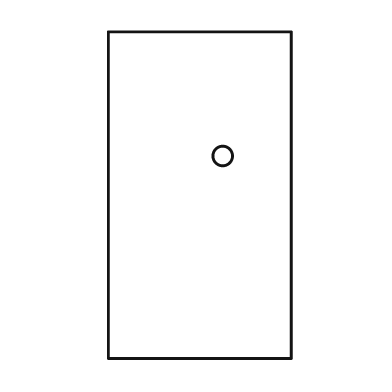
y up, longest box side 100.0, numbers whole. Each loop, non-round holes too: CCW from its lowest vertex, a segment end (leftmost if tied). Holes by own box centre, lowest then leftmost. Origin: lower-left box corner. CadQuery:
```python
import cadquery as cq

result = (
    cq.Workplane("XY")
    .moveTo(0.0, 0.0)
    .lineTo(56.0, 0.0)
    .lineTo(56.0, 100.0)
    .lineTo(0.0, 100.0)
    .close()
    .moveTo(35.0, 62.0)
    .circle(3.0)
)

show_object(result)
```